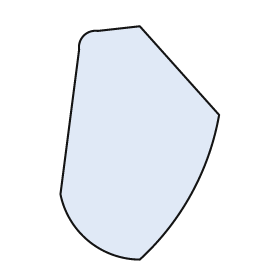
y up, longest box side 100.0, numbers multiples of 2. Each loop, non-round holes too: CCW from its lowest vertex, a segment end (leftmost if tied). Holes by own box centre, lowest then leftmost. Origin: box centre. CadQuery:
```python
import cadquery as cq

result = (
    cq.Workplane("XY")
    .moveTo(0.0, -50.0)
    .threePointArc((22.0, -22.0), (34.0, 12.0))
    .lineTo(0.0, 50.0)
    .lineTo(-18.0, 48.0)
    .threePointArc((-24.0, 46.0), (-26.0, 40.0))
    .lineTo(-34.0, -22.0)
    .threePointArc((-22.0, -42.0), (0.0, -50.0))
    .close()
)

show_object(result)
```